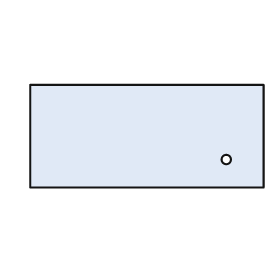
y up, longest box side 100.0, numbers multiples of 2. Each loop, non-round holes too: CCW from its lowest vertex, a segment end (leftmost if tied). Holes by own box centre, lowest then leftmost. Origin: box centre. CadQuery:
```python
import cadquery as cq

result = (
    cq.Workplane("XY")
    .moveTo(-50.0, -22.0)
    .lineTo(50.0, -22.0)
    .lineTo(50.0, 22.0)
    .lineTo(-50.0, 22.0)
    .close()
    .moveTo(34.0, -10.0)
    .circle(2.0)
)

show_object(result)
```